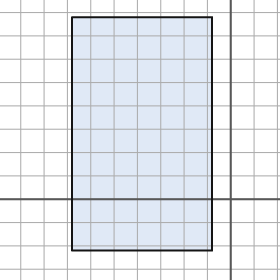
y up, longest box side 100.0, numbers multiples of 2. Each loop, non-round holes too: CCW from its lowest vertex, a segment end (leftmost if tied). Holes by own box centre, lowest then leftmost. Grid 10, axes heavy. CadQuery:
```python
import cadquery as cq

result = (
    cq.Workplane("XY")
    .moveTo(-68.0, -22.0)
    .lineTo(-8.0, -22.0)
    .lineTo(-8.0, 78.0)
    .lineTo(-68.0, 78.0)
    .close()
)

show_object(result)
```